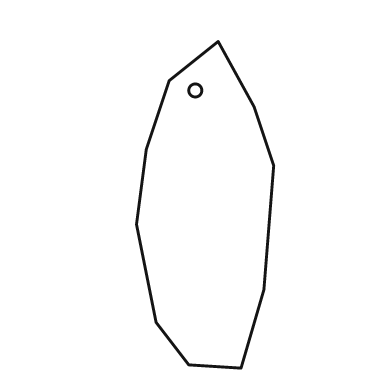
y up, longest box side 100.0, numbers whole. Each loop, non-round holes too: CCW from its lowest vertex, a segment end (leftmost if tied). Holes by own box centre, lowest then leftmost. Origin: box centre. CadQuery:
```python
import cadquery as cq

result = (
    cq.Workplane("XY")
    .moveTo(11.0, -50.0)
    .lineTo(18.0, -26.0)
    .lineTo(21.0, 12.0)
    .lineTo(15.0, 30.0)
    .lineTo(4.0, 50.0)
    .lineTo(-11.0, 38.0)
    .lineTo(-18.0, 17.0)
    .lineTo(-21.0, -6.0)
    .lineTo(-15.0, -36.0)
    .lineTo(-5.0, -49.0)
    .close()
    .moveTo(-3.0, 35.0)
    .circle(2.0)
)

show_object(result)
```